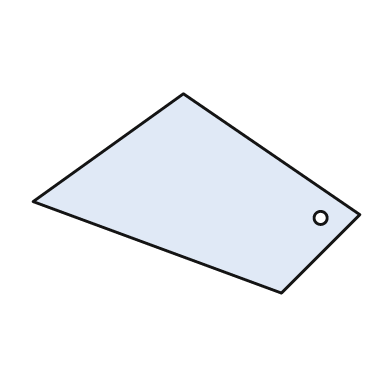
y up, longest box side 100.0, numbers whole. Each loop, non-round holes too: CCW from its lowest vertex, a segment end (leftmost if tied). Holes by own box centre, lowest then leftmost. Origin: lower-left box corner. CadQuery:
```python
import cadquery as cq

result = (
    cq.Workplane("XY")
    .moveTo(76.0, 0.0)
    .lineTo(100.0, 24.0)
    .lineTo(46.0, 61.0)
    .lineTo(0.0, 28.0)
    .close()
    .moveTo(88.0, 23.0)
    .circle(2.0)
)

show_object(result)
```